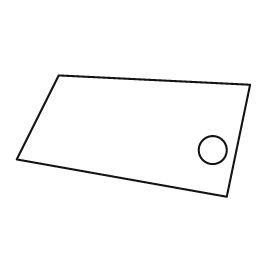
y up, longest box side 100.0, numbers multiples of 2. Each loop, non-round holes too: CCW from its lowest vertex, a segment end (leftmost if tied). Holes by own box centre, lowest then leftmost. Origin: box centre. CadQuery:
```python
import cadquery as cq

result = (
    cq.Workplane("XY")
    .moveTo(40.0, -26.0)
    .lineTo(50.0, 22.0)
    .lineTo(-32.0, 26.0)
    .lineTo(-50.0, -10.0)
    .close()
    .moveTo(34.0, -6.0)
    .circle(6.0)
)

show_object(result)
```